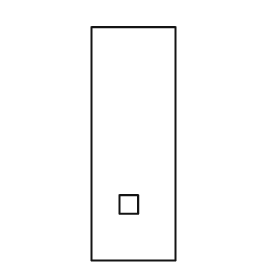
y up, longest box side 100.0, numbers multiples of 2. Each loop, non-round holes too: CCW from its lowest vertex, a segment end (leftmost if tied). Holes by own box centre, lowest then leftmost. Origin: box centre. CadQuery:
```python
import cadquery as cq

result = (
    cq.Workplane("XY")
    .moveTo(-18.0, -50.0)
    .lineTo(18.0, -50.0)
    .lineTo(18.0, 50.0)
    .lineTo(-18.0, 50.0)
    .close()
    .moveTo(-6.0, -30.0)
    .lineTo(2.0, -30.0)
    .lineTo(2.0, -22.0)
    .lineTo(-6.0, -22.0)
    .close()
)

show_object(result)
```